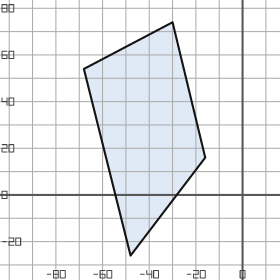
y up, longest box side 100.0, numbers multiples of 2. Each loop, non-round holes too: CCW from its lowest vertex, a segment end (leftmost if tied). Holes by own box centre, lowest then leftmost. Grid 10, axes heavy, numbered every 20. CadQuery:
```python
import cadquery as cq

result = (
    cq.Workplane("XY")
    .moveTo(-48.0, -26.0)
    .lineTo(-16.0, 16.0)
    .lineTo(-30.0, 74.0)
    .lineTo(-68.0, 54.0)
    .close()
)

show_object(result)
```